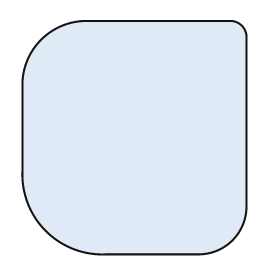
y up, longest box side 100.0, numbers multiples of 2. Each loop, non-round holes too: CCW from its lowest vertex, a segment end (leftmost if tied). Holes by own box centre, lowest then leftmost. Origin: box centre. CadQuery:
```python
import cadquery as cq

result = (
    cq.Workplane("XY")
    .moveTo(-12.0, -50.0)
    .lineTo(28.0, -50.0)
    .threePointArc((42.0, -44.0), (48.0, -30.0))
    .lineTo(48.0, 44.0)
    .threePointArc((46.0, 48.0), (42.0, 50.0))
    .lineTo(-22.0, 50.0)
    .threePointArc((-40.0, 42.0), (-48.0, 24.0))
    .lineTo(-48.0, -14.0)
    .threePointArc((-38.0, -40.0), (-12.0, -50.0))
    .close()
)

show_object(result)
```